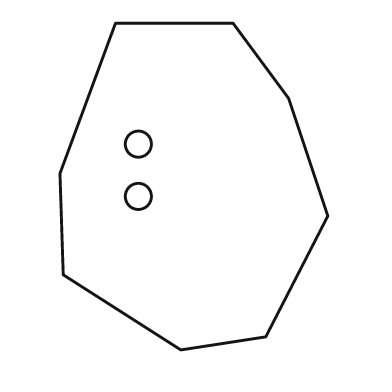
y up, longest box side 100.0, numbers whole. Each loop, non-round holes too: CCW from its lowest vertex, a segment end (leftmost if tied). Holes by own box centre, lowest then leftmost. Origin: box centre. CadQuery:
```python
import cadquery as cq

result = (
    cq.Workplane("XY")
    .moveTo(-4.0, -50.0)
    .lineTo(22.0, -46.0)
    .lineTo(41.0, -9.0)
    .lineTo(29.0, 27.0)
    .lineTo(12.0, 50.0)
    .lineTo(-24.0, 50.0)
    .lineTo(-41.0, 4.0)
    .lineTo(-40.0, -27.0)
    .close()
    .moveTo(-17.0, -3.0)
    .circle(4.0)
    .moveTo(-17.0, 13.0)
    .circle(4.0)
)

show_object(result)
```